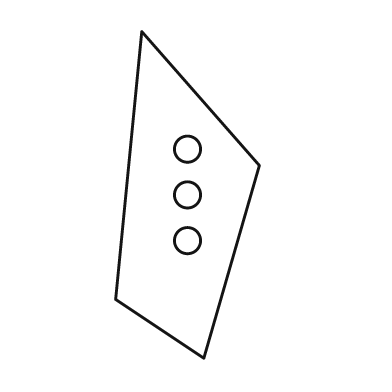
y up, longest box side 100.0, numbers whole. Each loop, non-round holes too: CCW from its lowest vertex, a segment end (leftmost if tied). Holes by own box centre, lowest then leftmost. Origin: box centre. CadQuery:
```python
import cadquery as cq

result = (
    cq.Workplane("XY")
    .moveTo(5.0, -50.0)
    .lineTo(22.0, 9.0)
    .lineTo(-14.0, 50.0)
    .lineTo(-22.0, -32.0)
    .close()
    .moveTo(0.0, -14.0)
    .circle(4.0)
    .moveTo(0.0, 0.0)
    .circle(4.0)
    .moveTo(0.0, 14.0)
    .circle(4.0)
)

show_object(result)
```